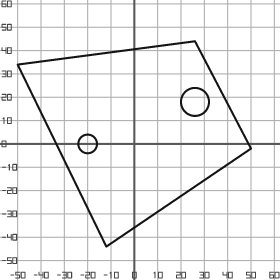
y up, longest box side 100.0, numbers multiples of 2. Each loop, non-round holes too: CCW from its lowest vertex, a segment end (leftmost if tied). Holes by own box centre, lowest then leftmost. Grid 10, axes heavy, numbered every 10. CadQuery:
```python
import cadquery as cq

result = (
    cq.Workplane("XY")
    .moveTo(-12.0, -44.0)
    .lineTo(50.0, -2.0)
    .lineTo(26.0, 44.0)
    .lineTo(-50.0, 34.0)
    .close()
    .moveTo(-20.0, 0.0)
    .circle(4.0)
    .moveTo(26.0, 18.0)
    .circle(6.0)
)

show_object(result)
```